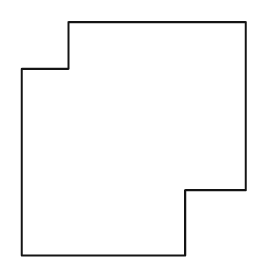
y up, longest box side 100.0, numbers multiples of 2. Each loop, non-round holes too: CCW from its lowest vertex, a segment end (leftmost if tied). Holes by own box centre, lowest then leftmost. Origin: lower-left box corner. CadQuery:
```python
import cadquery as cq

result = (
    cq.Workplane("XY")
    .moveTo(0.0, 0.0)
    .lineTo(70.0, 0.0)
    .lineTo(70.0, 28.0)
    .lineTo(96.0, 28.0)
    .lineTo(96.0, 100.0)
    .lineTo(20.0, 100.0)
    .lineTo(20.0, 80.0)
    .lineTo(0.0, 80.0)
    .close()
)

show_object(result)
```